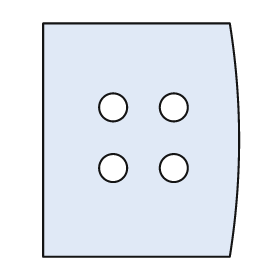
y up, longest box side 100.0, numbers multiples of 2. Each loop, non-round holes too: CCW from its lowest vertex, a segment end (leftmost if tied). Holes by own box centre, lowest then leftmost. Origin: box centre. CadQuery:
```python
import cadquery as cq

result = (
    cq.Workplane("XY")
    .moveTo(-42.0, -50.0)
    .lineTo(38.0, -50.0)
    .threePointArc((42.0, 0.0), (38.0, 50.0))
    .lineTo(-42.0, 50.0)
    .close()
    .moveTo(-12.0, -12.0)
    .circle(6.0)
    .moveTo(14.0, -12.0)
    .circle(6.0)
    .moveTo(-12.0, 14.0)
    .circle(6.0)
    .moveTo(14.0, 14.0)
    .circle(6.0)
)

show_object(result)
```